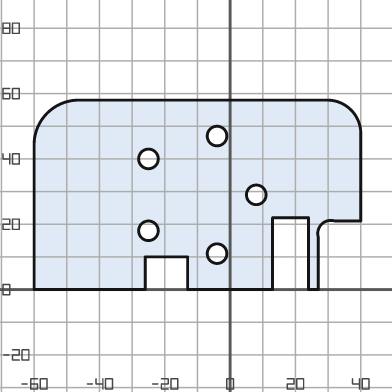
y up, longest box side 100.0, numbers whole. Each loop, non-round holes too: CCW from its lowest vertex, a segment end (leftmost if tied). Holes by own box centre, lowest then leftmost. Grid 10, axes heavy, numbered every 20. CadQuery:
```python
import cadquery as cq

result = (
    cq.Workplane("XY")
    .moveTo(-60.0, 0.0)
    .lineTo(-26.0, 0.0)
    .lineTo(-26.0, 10.0)
    .lineTo(-13.0, 10.0)
    .lineTo(-13.0, 0.0)
    .lineTo(13.0, 0.0)
    .lineTo(13.0, 22.0)
    .lineTo(24.0, 22.0)
    .lineTo(24.0, 0.0)
    .lineTo(27.0, 0.0)
    .lineTo(27.0, 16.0)
    .threePointArc((28.0, 20.0), (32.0, 21.0))
    .lineTo(40.0, 21.0)
    .lineTo(40.0, 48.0)
    .threePointArc((37.0, 55.0), (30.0, 58.0))
    .lineTo(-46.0, 58.0)
    .threePointArc((-56.0, 54.0), (-60.0, 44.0))
    .close()
    .moveTo(-4.0, 11.0)
    .circle(3.0)
    .moveTo(-25.0, 18.0)
    .circle(3.0)
    .moveTo(8.0, 29.0)
    .circle(3.0)
    .moveTo(-25.0, 40.0)
    .circle(3.0)
    .moveTo(-4.0, 47.0)
    .circle(3.0)
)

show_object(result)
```